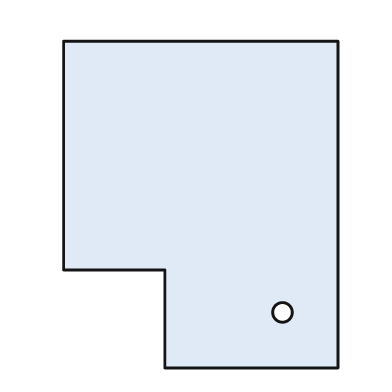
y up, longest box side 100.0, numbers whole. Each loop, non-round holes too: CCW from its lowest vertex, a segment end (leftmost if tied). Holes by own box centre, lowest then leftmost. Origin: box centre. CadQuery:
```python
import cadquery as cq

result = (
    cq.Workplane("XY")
    .moveTo(-11.0, -50.0)
    .lineTo(42.0, -50.0)
    .lineTo(42.0, 50.0)
    .lineTo(-42.0, 50.0)
    .lineTo(-42.0, -20.0)
    .lineTo(-11.0, -20.0)
    .close()
    .moveTo(25.0, -33.0)
    .circle(3.0)
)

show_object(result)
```